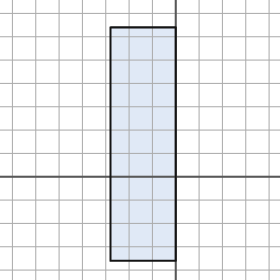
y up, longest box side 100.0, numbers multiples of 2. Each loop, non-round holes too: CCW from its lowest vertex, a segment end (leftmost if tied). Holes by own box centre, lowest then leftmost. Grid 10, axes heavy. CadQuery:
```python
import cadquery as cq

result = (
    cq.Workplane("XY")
    .moveTo(-28.0, -36.0)
    .lineTo(0.0, -36.0)
    .lineTo(0.0, 64.0)
    .lineTo(-28.0, 64.0)
    .close()
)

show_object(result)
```